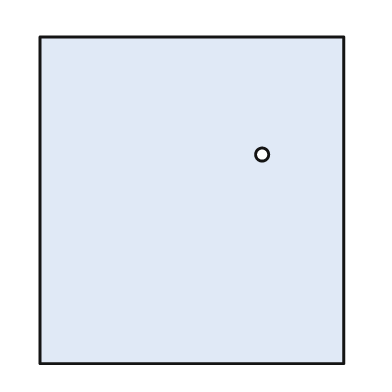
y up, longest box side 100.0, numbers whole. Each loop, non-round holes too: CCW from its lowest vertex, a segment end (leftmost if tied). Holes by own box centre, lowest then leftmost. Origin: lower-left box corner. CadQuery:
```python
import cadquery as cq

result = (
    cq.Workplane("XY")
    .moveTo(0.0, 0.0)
    .lineTo(93.0, 0.0)
    .lineTo(93.0, 100.0)
    .lineTo(0.0, 100.0)
    .close()
    .moveTo(68.0, 64.0)
    .circle(2.0)
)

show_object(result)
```